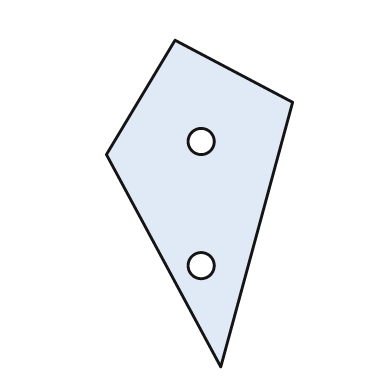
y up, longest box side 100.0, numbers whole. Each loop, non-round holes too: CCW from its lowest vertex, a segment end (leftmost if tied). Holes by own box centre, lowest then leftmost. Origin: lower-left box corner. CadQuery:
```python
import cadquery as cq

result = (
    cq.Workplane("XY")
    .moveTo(35.0, 0.0)
    .lineTo(57.0, 81.0)
    .lineTo(21.0, 100.0)
    .lineTo(0.0, 65.0)
    .close()
    .moveTo(29.0, 31.0)
    .circle(4.0)
    .moveTo(29.0, 69.0)
    .circle(4.0)
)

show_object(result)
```